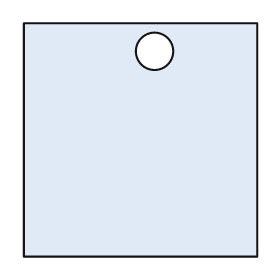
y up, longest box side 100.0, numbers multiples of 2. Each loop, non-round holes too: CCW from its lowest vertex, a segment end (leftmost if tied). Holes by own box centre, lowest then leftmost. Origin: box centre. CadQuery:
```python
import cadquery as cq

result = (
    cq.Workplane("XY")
    .moveTo(-50.0, -50.0)
    .lineTo(50.0, -50.0)
    .lineTo(50.0, 50.0)
    .lineTo(-50.0, 50.0)
    .close()
    .moveTo(6.0, 38.0)
    .circle(8.0)
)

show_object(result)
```